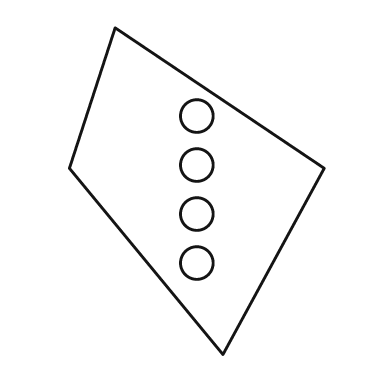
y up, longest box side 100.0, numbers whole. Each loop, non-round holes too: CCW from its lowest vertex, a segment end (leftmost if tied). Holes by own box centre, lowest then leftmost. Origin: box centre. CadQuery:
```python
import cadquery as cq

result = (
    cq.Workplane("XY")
    .moveTo(8.0, -50.0)
    .lineTo(39.0, 7.0)
    .lineTo(-25.0, 50.0)
    .lineTo(-39.0, 7.0)
    .close()
    .moveTo(0.0, -22.0)
    .circle(5.0)
    .moveTo(0.0, -7.0)
    .circle(5.0)
    .moveTo(0.0, 8.0)
    .circle(5.0)
    .moveTo(0.0, 23.0)
    .circle(5.0)
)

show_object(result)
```